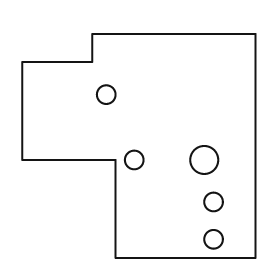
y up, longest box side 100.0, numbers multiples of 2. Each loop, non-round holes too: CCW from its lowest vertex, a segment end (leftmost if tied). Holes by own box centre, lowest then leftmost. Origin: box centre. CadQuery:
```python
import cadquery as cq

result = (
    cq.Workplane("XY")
    .moveTo(-10.0, -48.0)
    .lineTo(50.0, -48.0)
    .lineTo(50.0, 48.0)
    .lineTo(-20.0, 48.0)
    .lineTo(-20.0, 36.0)
    .lineTo(-50.0, 36.0)
    .lineTo(-50.0, -6.0)
    .lineTo(-10.0, -6.0)
    .close()
    .moveTo(32.0, -40.0)
    .circle(4.0)
    .moveTo(32.0, -24.0)
    .circle(4.0)
    .moveTo(-2.0, -6.0)
    .circle(4.0)
    .moveTo(28.0, -6.0)
    .circle(6.0)
    .moveTo(-14.0, 22.0)
    .circle(4.0)
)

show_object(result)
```